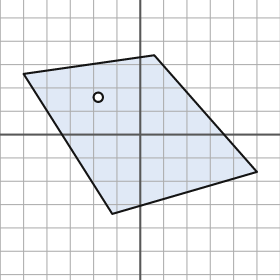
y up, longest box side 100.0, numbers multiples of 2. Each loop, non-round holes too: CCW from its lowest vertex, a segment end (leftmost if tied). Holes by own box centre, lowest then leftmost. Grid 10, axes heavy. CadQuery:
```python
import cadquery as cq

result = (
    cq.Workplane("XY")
    .moveTo(-12.0, -34.0)
    .lineTo(50.0, -16.0)
    .lineTo(6.0, 34.0)
    .lineTo(-50.0, 26.0)
    .close()
    .moveTo(-18.0, 16.0)
    .circle(2.0)
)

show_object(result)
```